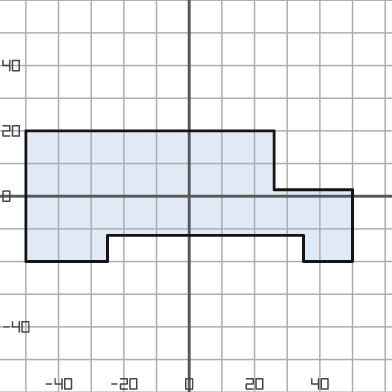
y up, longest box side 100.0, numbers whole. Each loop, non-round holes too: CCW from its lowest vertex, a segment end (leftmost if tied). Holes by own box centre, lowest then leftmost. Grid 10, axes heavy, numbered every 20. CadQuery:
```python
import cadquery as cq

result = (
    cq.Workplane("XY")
    .moveTo(-50.0, -20.0)
    .lineTo(-25.0, -20.0)
    .lineTo(-25.0, -12.0)
    .lineTo(35.0, -12.0)
    .lineTo(35.0, -20.0)
    .lineTo(50.0, -20.0)
    .lineTo(50.0, 2.0)
    .lineTo(26.0, 2.0)
    .lineTo(26.0, 20.0)
    .lineTo(-50.0, 20.0)
    .close()
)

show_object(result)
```